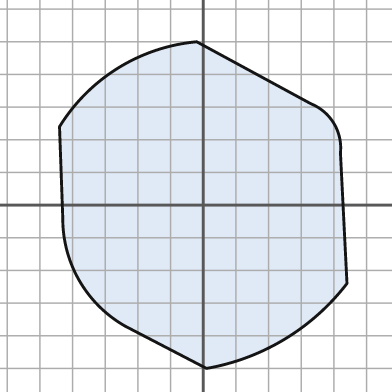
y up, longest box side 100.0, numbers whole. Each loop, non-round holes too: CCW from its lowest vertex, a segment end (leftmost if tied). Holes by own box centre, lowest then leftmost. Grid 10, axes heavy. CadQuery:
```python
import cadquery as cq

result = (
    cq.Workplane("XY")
    .moveTo(1.0, -50.0)
    .threePointArc((25.0, -41.0), (44.0, -24.0))
    .lineTo(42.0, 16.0)
    .threePointArc((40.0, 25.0), (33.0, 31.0))
    .lineTo(-2.0, 50.0)
    .threePointArc((-26.0, 42.0), (-44.0, 24.0))
    .lineTo(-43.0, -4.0)
    .threePointArc((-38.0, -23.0), (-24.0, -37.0))
    .close()
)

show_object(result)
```